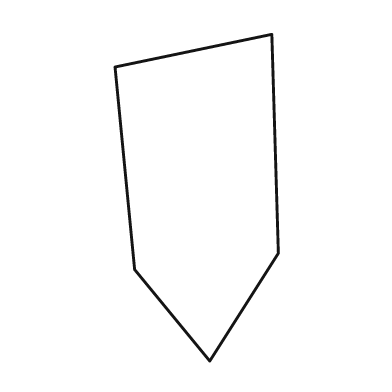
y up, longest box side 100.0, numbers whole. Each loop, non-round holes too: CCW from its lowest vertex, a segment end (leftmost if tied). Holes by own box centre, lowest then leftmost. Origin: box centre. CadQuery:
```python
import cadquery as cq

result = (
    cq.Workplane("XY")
    .moveTo(4.0, -50.0)
    .lineTo(25.0, -17.0)
    .lineTo(23.0, 50.0)
    .lineTo(-25.0, 40.0)
    .lineTo(-19.0, -22.0)
    .close()
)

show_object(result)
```